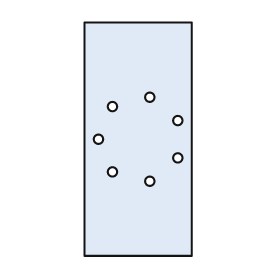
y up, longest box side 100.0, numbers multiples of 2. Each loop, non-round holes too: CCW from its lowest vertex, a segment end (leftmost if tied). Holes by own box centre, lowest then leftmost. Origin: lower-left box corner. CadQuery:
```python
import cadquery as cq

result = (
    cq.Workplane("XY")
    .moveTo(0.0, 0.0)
    .lineTo(46.0, 0.0)
    .lineTo(46.0, 100.0)
    .lineTo(0.0, 100.0)
    .close()
    .moveTo(28.0, 32.0)
    .circle(2.0)
    .moveTo(12.0, 36.0)
    .circle(2.0)
    .moveTo(40.0, 42.0)
    .circle(2.0)
    .moveTo(6.0, 50.0)
    .circle(2.0)
    .moveTo(40.0, 58.0)
    .circle(2.0)
    .moveTo(12.0, 64.0)
    .circle(2.0)
    .moveTo(28.0, 68.0)
    .circle(2.0)
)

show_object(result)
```